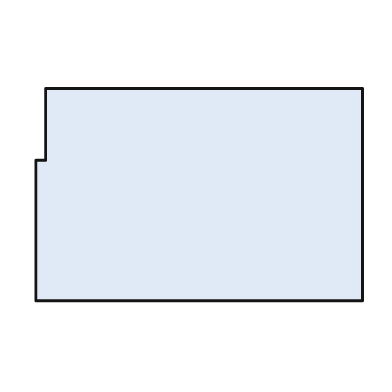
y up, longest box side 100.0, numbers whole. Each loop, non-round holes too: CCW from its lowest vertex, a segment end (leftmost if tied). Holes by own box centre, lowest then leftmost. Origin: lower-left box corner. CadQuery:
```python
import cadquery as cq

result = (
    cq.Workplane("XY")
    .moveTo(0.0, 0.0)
    .lineTo(100.0, 0.0)
    .lineTo(100.0, 65.0)
    .lineTo(3.0, 65.0)
    .lineTo(3.0, 43.0)
    .lineTo(0.0, 43.0)
    .close()
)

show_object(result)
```